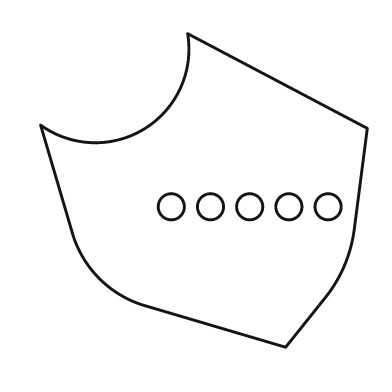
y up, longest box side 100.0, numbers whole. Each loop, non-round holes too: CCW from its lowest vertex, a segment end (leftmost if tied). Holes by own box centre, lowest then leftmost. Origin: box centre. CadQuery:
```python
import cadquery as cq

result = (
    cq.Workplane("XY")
    .moveTo(25.0, -48.0)
    .lineTo(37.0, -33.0)
    .threePointArc((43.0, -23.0), (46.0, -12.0))
    .lineTo(50.0, 19.0)
    .lineTo(-5.0, 48.0)
    .threePointArc((-18.0, 19.0), (-50.0, 20.0))
    .lineTo(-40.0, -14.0)
    .threePointArc((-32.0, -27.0), (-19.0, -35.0))
    .close()
    .moveTo(-10.0, -5.0)
    .circle(4.0)
    .moveTo(2.0, -5.0)
    .circle(4.0)
    .moveTo(14.0, -5.0)
    .circle(4.0)
    .moveTo(26.0, -5.0)
    .circle(4.0)
    .moveTo(38.0, -5.0)
    .circle(4.0)
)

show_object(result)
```